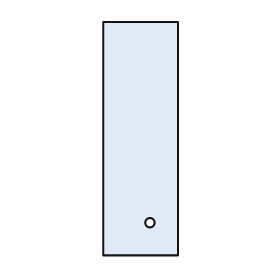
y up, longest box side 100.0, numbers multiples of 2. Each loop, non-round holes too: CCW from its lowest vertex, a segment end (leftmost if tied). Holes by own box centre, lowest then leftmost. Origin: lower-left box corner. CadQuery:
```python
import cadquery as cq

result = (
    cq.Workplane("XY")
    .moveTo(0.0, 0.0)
    .lineTo(32.0, 0.0)
    .lineTo(32.0, 100.0)
    .lineTo(0.0, 100.0)
    .close()
    .moveTo(20.0, 14.0)
    .circle(2.0)
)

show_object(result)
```